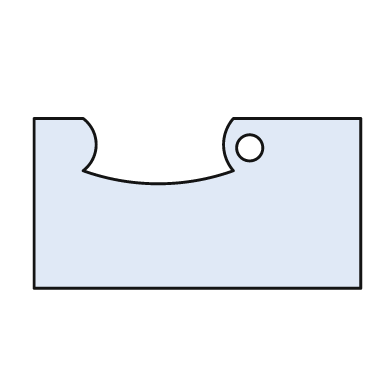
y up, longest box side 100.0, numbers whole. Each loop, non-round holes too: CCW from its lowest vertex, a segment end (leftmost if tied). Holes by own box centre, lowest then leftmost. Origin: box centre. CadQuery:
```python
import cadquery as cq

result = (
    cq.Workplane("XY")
    .moveTo(-50.0, -26.0)
    .lineTo(50.0, -26.0)
    .lineTo(50.0, 26.0)
    .lineTo(11.0, 26.0)
    .threePointArc((8.0, 18.0), (11.0, 10.0))
    .threePointArc((-12.0, 6.0), (-35.0, 10.0))
    .threePointArc((-31.0, 18.0), (-35.0, 26.0))
    .lineTo(-50.0, 26.0)
    .close()
    .moveTo(16.0, 17.0)
    .circle(4.0)
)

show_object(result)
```